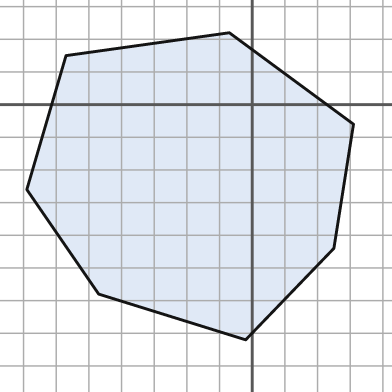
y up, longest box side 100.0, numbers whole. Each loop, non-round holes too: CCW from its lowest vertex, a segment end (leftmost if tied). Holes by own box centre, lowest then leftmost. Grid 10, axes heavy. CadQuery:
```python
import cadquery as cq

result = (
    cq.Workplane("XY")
    .moveTo(-2.0, -72.0)
    .lineTo(25.0, -44.0)
    .lineTo(31.0, -6.0)
    .lineTo(-7.0, 22.0)
    .lineTo(-57.0, 15.0)
    .lineTo(-69.0, -26.0)
    .lineTo(-47.0, -58.0)
    .close()
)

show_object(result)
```